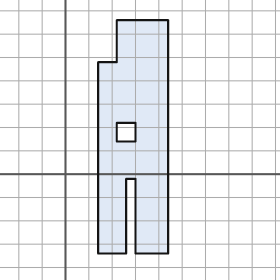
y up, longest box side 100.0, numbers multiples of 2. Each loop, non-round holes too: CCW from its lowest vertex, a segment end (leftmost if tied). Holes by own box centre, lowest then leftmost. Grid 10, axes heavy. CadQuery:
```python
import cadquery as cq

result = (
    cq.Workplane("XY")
    .moveTo(14.0, -34.0)
    .lineTo(26.0, -34.0)
    .lineTo(26.0, -2.0)
    .lineTo(30.0, -2.0)
    .lineTo(30.0, -34.0)
    .lineTo(44.0, -34.0)
    .lineTo(44.0, 66.0)
    .lineTo(22.0, 66.0)
    .lineTo(22.0, 48.0)
    .lineTo(14.0, 48.0)
    .close()
    .moveTo(22.0, 14.0)
    .lineTo(30.0, 14.0)
    .lineTo(30.0, 22.0)
    .lineTo(22.0, 22.0)
    .close()
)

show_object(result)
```